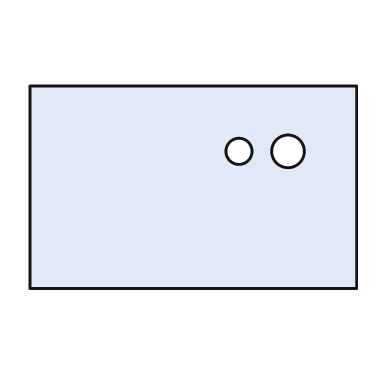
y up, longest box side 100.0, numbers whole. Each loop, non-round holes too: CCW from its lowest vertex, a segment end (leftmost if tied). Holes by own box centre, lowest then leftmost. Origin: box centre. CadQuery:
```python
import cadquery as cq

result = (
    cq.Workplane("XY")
    .moveTo(-50.0, -31.0)
    .lineTo(50.0, -31.0)
    .lineTo(50.0, 31.0)
    .lineTo(-50.0, 31.0)
    .close()
    .moveTo(14.0, 11.0)
    .circle(4.0)
    .moveTo(29.0, 11.0)
    .circle(5.0)
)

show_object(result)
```